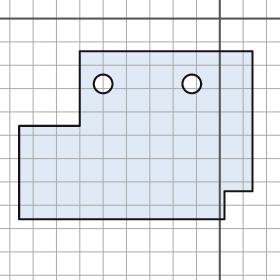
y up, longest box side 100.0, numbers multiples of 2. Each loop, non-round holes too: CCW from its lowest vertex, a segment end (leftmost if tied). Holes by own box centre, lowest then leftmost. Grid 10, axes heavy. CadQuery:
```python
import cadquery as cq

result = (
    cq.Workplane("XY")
    .moveTo(-86.0, -86.0)
    .lineTo(2.0, -86.0)
    .lineTo(2.0, -74.0)
    .lineTo(14.0, -74.0)
    .lineTo(14.0, -14.0)
    .lineTo(-60.0, -14.0)
    .lineTo(-60.0, -46.0)
    .lineTo(-86.0, -46.0)
    .close()
    .moveTo(-50.0, -28.0)
    .circle(4.0)
    .moveTo(-12.0, -28.0)
    .circle(4.0)
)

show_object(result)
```